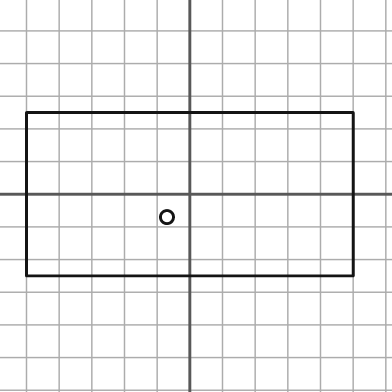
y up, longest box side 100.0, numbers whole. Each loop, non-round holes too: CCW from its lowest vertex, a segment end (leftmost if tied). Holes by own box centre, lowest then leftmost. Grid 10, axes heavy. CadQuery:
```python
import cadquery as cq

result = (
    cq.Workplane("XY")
    .moveTo(-50.0, -25.0)
    .lineTo(50.0, -25.0)
    .lineTo(50.0, 25.0)
    .lineTo(-50.0, 25.0)
    .close()
    .moveTo(-7.0, -7.0)
    .circle(2.0)
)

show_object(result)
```